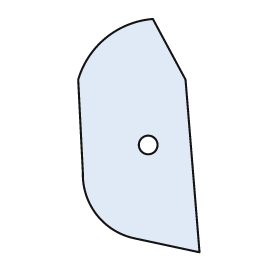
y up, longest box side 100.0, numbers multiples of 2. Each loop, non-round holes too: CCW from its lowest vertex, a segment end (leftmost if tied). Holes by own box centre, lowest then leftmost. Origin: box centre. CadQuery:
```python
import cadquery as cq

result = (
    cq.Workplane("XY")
    .moveTo(26.0, -50.0)
    .lineTo(20.0, 24.0)
    .lineTo(6.0, 50.0)
    .threePointArc((-14.0, 42.0), (-26.0, 24.0))
    .lineTo(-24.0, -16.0)
    .threePointArc((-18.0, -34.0), (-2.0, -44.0))
    .close()
    .moveTo(4.0, -4.0)
    .circle(4.0)
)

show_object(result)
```